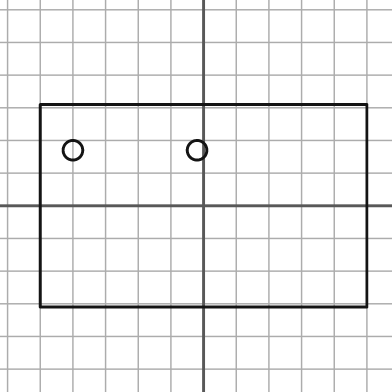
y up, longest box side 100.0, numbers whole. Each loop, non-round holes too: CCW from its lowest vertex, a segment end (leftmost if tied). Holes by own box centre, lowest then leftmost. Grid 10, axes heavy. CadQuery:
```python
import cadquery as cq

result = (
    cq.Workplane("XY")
    .moveTo(-50.0, -31.0)
    .lineTo(50.0, -31.0)
    .lineTo(50.0, 31.0)
    .lineTo(-50.0, 31.0)
    .close()
    .moveTo(-40.0, 17.0)
    .circle(3.0)
    .moveTo(-2.0, 17.0)
    .circle(3.0)
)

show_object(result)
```